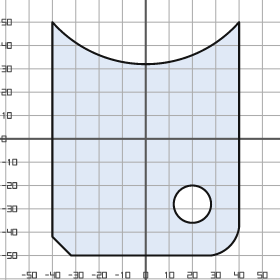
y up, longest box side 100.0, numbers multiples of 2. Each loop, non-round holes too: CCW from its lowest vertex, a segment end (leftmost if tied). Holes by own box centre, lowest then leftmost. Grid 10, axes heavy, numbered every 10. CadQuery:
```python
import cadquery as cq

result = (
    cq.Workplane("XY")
    .moveTo(-32.0, -50.0)
    .lineTo(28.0, -50.0)
    .threePointArc((36.0, -46.0), (40.0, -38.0))
    .lineTo(40.0, 50.0)
    .threePointArc((0.0, 32.0), (-40.0, 50.0))
    .lineTo(-40.0, -42.0)
    .close()
    .moveTo(20.0, -28.0)
    .circle(8.0)
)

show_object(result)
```